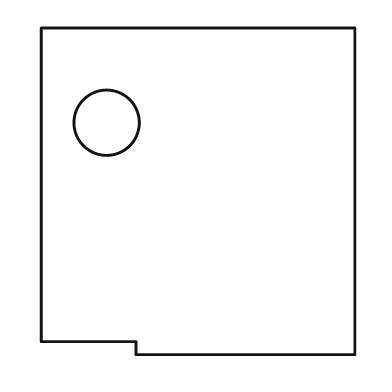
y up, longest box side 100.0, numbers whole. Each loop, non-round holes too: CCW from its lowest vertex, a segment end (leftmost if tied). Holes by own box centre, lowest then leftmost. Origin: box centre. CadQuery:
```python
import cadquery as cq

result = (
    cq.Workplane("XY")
    .moveTo(-19.0, -50.0)
    .lineTo(48.0, -50.0)
    .lineTo(48.0, 50.0)
    .lineTo(-48.0, 50.0)
    .lineTo(-48.0, -46.0)
    .lineTo(-19.0, -46.0)
    .close()
    .moveTo(-28.0, 21.0)
    .circle(10.0)
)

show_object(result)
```